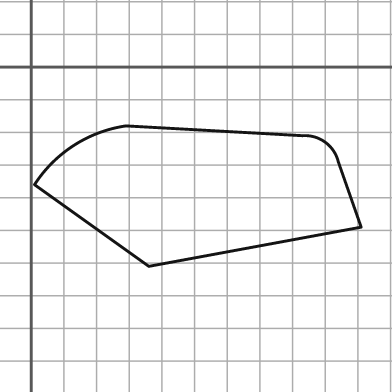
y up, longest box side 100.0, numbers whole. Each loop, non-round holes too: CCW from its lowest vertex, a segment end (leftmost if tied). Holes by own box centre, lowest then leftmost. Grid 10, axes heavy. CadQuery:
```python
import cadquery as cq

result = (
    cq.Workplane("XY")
    .moveTo(36.0, -61.0)
    .lineTo(101.0, -49.0)
    .lineTo(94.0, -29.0)
    .threePointArc((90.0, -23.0), (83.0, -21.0))
    .lineTo(29.0, -18.0)
    .threePointArc((13.0, -24.0), (1.0, -36.0))
    .close()
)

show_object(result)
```